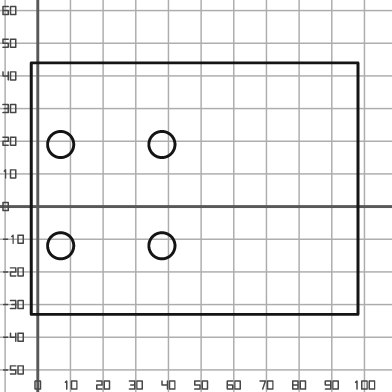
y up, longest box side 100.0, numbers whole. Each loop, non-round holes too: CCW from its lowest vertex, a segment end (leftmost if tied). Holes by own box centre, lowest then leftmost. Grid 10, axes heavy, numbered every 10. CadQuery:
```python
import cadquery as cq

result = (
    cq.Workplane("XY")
    .moveTo(-2.0, -33.0)
    .lineTo(98.0, -33.0)
    .lineTo(98.0, 44.0)
    .lineTo(-2.0, 44.0)
    .close()
    .moveTo(7.0, -12.0)
    .circle(4.0)
    .moveTo(38.0, -12.0)
    .circle(4.0)
    .moveTo(7.0, 19.0)
    .circle(4.0)
    .moveTo(38.0, 19.0)
    .circle(4.0)
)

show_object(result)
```